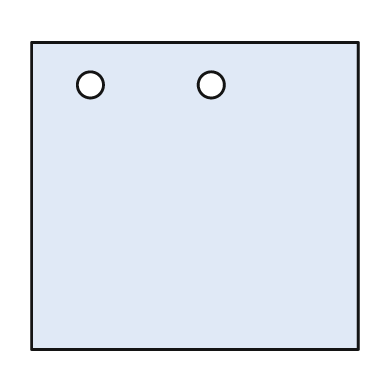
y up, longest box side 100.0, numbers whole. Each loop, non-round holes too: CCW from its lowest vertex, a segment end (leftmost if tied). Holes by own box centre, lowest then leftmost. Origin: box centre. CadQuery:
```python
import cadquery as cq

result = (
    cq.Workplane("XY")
    .moveTo(-50.0, -47.0)
    .lineTo(50.0, -47.0)
    .lineTo(50.0, 47.0)
    .lineTo(-50.0, 47.0)
    .close()
    .moveTo(-32.0, 34.0)
    .circle(4.0)
    .moveTo(5.0, 34.0)
    .circle(4.0)
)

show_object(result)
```